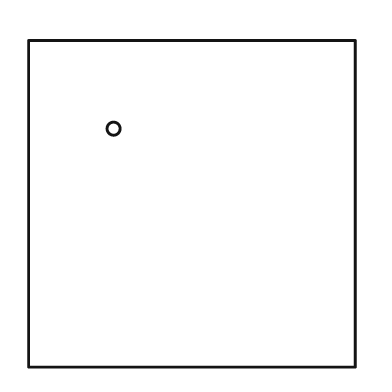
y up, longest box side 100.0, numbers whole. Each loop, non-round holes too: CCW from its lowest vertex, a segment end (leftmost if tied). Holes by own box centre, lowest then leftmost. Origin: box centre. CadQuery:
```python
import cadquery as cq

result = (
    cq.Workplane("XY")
    .moveTo(-50.0, -50.0)
    .lineTo(50.0, -50.0)
    .lineTo(50.0, 50.0)
    .lineTo(-50.0, 50.0)
    .close()
    .moveTo(-24.0, 23.0)
    .circle(2.0)
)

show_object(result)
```